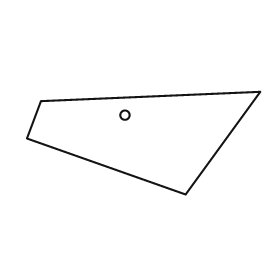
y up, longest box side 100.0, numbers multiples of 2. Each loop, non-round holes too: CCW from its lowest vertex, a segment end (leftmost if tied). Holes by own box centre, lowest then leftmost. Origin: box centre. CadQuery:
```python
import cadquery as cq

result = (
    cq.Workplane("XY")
    .moveTo(18.0, -22.0)
    .lineTo(50.0, 22.0)
    .lineTo(-44.0, 18.0)
    .lineTo(-50.0, 2.0)
    .close()
    .moveTo(-8.0, 12.0)
    .circle(2.0)
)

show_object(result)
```